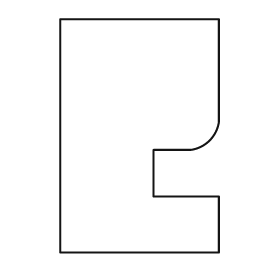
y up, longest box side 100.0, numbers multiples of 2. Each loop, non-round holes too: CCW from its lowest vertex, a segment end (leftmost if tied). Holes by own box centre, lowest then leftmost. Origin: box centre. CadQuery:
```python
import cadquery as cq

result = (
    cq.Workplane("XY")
    .moveTo(-34.0, -50.0)
    .lineTo(34.0, -50.0)
    .lineTo(34.0, -26.0)
    .lineTo(6.0, -26.0)
    .lineTo(6.0, -6.0)
    .lineTo(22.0, -6.0)
    .threePointArc((30.0, -2.0), (34.0, 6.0))
    .lineTo(34.0, 50.0)
    .lineTo(-34.0, 50.0)
    .close()
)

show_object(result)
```